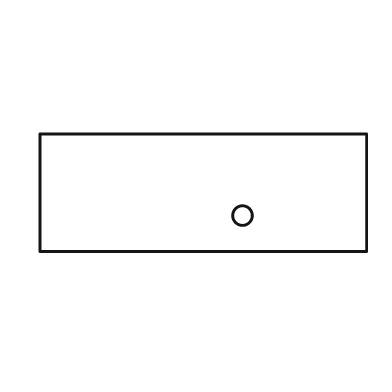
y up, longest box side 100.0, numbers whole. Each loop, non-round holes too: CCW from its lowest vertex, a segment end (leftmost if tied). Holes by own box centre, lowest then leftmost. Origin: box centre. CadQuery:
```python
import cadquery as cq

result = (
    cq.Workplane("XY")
    .moveTo(-50.0, -18.0)
    .lineTo(50.0, -18.0)
    .lineTo(50.0, 18.0)
    .lineTo(-50.0, 18.0)
    .close()
    .moveTo(12.0, -7.0)
    .circle(3.0)
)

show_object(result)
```